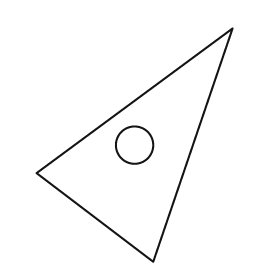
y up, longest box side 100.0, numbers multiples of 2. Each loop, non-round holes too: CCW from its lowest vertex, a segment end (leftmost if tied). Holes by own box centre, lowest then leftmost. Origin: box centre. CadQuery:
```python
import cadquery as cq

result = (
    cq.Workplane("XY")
    .moveTo(8.0, -50.0)
    .lineTo(42.0, 50.0)
    .lineTo(-42.0, -12.0)
    .close()
    .moveTo(0.0, 0.0)
    .circle(8.0)
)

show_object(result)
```